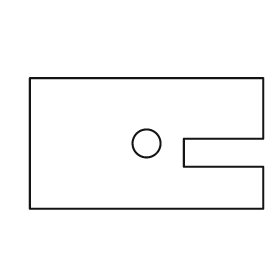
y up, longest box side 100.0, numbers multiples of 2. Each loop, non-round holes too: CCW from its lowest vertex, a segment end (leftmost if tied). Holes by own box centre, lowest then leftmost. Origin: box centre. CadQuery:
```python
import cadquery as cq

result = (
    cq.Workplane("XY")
    .moveTo(-50.0, -28.0)
    .lineTo(50.0, -28.0)
    .lineTo(50.0, -10.0)
    .lineTo(16.0, -10.0)
    .lineTo(16.0, 2.0)
    .lineTo(50.0, 2.0)
    .lineTo(50.0, 28.0)
    .lineTo(-50.0, 28.0)
    .close()
    .moveTo(0.0, 0.0)
    .circle(6.0)
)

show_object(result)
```